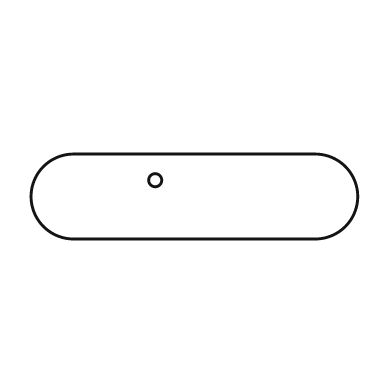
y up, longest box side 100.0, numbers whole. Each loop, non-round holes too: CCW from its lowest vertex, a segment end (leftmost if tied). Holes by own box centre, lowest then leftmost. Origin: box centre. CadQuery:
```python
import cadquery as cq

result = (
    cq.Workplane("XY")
    .moveTo(-37.0, -13.0)
    .lineTo(37.0, -13.0)
    .threePointArc((50.0, 0.0), (37.0, 13.0))
    .lineTo(-37.0, 13.0)
    .threePointArc((-50.0, 0.0), (-37.0, -13.0))
    .close()
    .moveTo(-12.0, 5.0)
    .circle(2.0)
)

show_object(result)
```